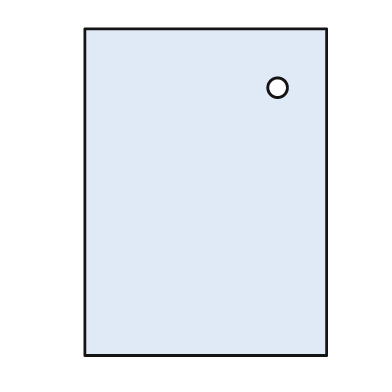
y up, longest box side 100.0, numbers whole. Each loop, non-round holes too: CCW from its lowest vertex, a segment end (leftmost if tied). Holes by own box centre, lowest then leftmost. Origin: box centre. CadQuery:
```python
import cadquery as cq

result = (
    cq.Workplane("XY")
    .moveTo(-37.0, -50.0)
    .lineTo(37.0, -50.0)
    .lineTo(37.0, 50.0)
    .lineTo(-37.0, 50.0)
    .close()
    .moveTo(22.0, 32.0)
    .circle(3.0)
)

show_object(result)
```